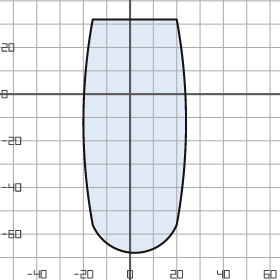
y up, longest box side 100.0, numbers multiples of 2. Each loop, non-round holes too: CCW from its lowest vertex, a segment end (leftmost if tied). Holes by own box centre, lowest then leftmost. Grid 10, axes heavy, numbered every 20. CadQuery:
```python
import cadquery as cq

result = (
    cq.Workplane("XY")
    .moveTo(-16.0, -56.0)
    .threePointArc((2.0, -68.0), (20.0, -56.0))
    .threePointArc((24.0, -12.0), (20.0, 32.0))
    .lineTo(-16.0, 32.0)
    .threePointArc((-20.0, -12.0), (-16.0, -56.0))
    .close()
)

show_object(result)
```